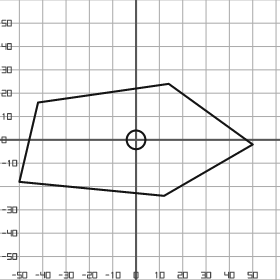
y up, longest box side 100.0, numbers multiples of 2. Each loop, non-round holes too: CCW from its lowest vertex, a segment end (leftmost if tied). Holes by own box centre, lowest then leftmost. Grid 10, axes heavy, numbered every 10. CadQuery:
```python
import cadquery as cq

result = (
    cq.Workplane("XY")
    .moveTo(12.0, -24.0)
    .lineTo(50.0, -2.0)
    .lineTo(14.0, 24.0)
    .lineTo(-42.0, 16.0)
    .lineTo(-50.0, -18.0)
    .close()
    .moveTo(0.0, 0.0)
    .circle(4.0)
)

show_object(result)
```